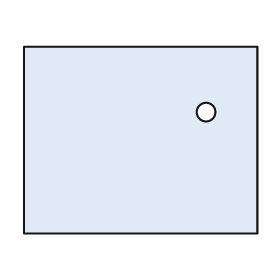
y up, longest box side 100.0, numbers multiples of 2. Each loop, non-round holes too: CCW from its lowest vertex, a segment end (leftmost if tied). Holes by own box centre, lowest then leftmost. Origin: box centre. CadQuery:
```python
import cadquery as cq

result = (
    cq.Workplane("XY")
    .moveTo(-50.0, -40.0)
    .lineTo(50.0, -40.0)
    .lineTo(50.0, 40.0)
    .lineTo(-50.0, 40.0)
    .close()
    .moveTo(28.0, 12.0)
    .circle(4.0)
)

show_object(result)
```